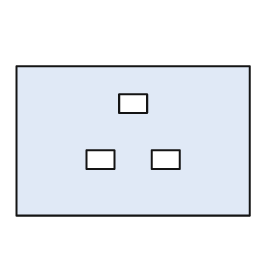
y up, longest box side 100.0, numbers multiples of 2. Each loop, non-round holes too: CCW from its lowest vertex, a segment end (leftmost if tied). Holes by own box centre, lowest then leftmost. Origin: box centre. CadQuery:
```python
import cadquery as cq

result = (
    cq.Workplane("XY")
    .moveTo(-50.0, -32.0)
    .lineTo(50.0, -32.0)
    .lineTo(50.0, 32.0)
    .lineTo(-50.0, 32.0)
    .close()
    .moveTo(-20.0, -12.0)
    .lineTo(-8.0, -12.0)
    .lineTo(-8.0, -4.0)
    .lineTo(-20.0, -4.0)
    .close()
    .moveTo(8.0, -12.0)
    .lineTo(20.0, -12.0)
    .lineTo(20.0, -4.0)
    .lineTo(8.0, -4.0)
    .close()
    .moveTo(-6.0, 12.0)
    .lineTo(6.0, 12.0)
    .lineTo(6.0, 20.0)
    .lineTo(-6.0, 20.0)
    .close()
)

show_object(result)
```